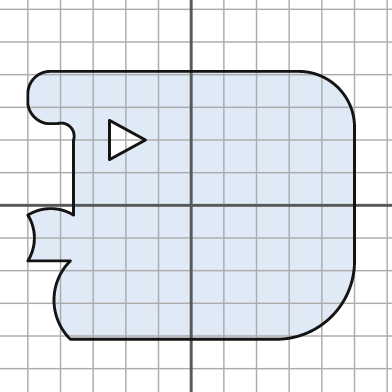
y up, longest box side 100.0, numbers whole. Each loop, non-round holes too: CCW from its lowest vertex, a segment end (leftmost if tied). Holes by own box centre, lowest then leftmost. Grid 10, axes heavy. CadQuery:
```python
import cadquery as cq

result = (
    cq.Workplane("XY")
    .moveTo(-37.0, -41.0)
    .lineTo(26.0, -41.0)
    .threePointArc((43.0, -34.0), (50.0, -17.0))
    .lineTo(50.0, 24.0)
    .threePointArc((45.0, 36.0), (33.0, 41.0))
    .lineTo(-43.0, 41.0)
    .threePointArc((-48.0, 39.0), (-50.0, 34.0))
    .lineTo(-50.0, 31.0)
    .threePointArc((-48.0, 27.0), (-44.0, 25.0))
    .lineTo(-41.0, 25.0)
    .threePointArc((-37.0, 24.0), (-36.0, 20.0))
    .lineTo(-36.0, -3.0)
    .threePointArc((-43.0, -1.0), (-50.0, -3.0))
    .threePointArc((-48.0, -10.0), (-50.0, -17.0))
    .lineTo(-37.0, -17.0)
    .threePointArc((-42.0, -29.0), (-37.0, -41.0))
    .close()
    .moveTo(-25.0, 14.0)
    .lineTo(-14.0, 20.0)
    .lineTo(-25.0, 26.0)
    .close()
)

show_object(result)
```